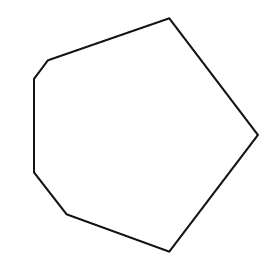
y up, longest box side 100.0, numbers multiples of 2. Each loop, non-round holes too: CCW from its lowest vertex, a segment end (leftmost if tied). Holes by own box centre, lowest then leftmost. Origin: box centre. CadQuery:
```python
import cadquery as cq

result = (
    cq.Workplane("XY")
    .moveTo(10.0, -50.0)
    .lineTo(48.0, 0.0)
    .lineTo(10.0, 50.0)
    .lineTo(-42.0, 32.0)
    .lineTo(-48.0, 24.0)
    .lineTo(-48.0, -16.0)
    .lineTo(-34.0, -34.0)
    .close()
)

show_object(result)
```